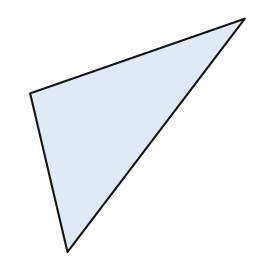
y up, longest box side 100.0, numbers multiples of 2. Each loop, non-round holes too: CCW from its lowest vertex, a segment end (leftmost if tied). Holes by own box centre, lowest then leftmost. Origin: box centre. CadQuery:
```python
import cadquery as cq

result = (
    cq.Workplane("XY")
    .moveTo(-30.0, -50.0)
    .lineTo(46.0, 50.0)
    .lineTo(-46.0, 18.0)
    .close()
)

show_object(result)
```